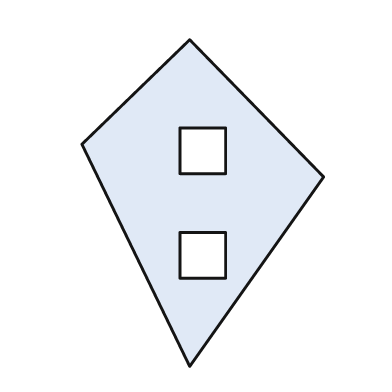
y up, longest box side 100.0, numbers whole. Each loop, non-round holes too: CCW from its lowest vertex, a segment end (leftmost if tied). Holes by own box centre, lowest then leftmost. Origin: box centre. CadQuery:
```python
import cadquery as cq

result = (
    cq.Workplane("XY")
    .moveTo(-4.0, -50.0)
    .lineTo(37.0, 8.0)
    .lineTo(-4.0, 50.0)
    .lineTo(-37.0, 18.0)
    .close()
    .moveTo(-7.0, -23.0)
    .lineTo(7.0, -23.0)
    .lineTo(7.0, -9.0)
    .lineTo(-7.0, -9.0)
    .close()
    .moveTo(-7.0, 9.0)
    .lineTo(7.0, 9.0)
    .lineTo(7.0, 23.0)
    .lineTo(-7.0, 23.0)
    .close()
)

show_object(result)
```